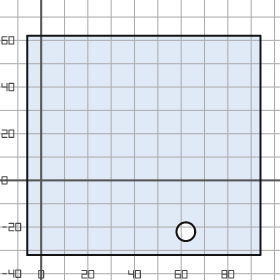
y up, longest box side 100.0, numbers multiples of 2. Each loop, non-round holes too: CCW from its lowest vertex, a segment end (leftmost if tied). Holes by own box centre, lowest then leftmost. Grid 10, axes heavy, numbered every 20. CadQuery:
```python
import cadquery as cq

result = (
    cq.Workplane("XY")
    .moveTo(-6.0, -32.0)
    .lineTo(94.0, -32.0)
    .lineTo(94.0, 62.0)
    .lineTo(-6.0, 62.0)
    .close()
    .moveTo(62.0, -22.0)
    .circle(4.0)
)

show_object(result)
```